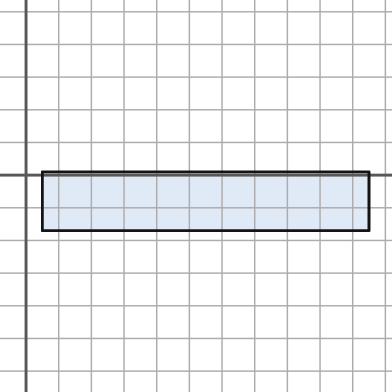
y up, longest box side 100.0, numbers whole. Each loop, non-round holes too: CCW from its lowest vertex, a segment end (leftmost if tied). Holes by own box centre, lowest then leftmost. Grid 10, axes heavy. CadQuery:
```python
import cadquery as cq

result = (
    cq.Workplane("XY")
    .moveTo(5.0, -17.0)
    .lineTo(105.0, -17.0)
    .lineTo(105.0, 1.0)
    .lineTo(5.0, 1.0)
    .close()
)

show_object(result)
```